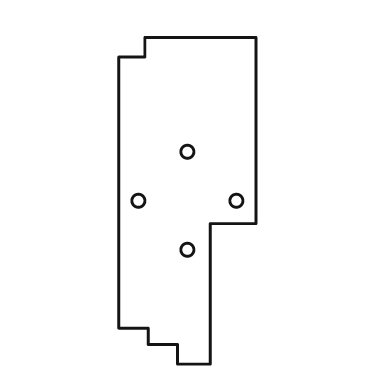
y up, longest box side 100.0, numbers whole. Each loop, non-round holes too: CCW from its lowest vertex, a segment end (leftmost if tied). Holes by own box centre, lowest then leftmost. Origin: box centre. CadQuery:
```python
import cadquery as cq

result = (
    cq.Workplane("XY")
    .moveTo(-3.0, -50.0)
    .lineTo(7.0, -50.0)
    .lineTo(7.0, -7.0)
    .lineTo(21.0, -7.0)
    .lineTo(21.0, 50.0)
    .lineTo(-13.0, 50.0)
    .lineTo(-13.0, 44.0)
    .lineTo(-21.0, 44.0)
    .lineTo(-21.0, -39.0)
    .lineTo(-12.0, -39.0)
    .lineTo(-12.0, -44.0)
    .lineTo(-3.0, -44.0)
    .close()
    .moveTo(0.0, -15.0)
    .circle(2.0)
    .moveTo(-15.0, 0.0)
    .circle(2.0)
    .moveTo(15.0, 0.0)
    .circle(2.0)
    .moveTo(0.0, 15.0)
    .circle(2.0)
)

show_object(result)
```